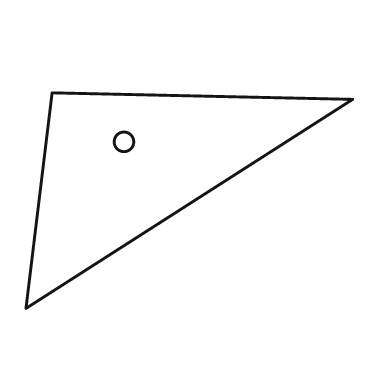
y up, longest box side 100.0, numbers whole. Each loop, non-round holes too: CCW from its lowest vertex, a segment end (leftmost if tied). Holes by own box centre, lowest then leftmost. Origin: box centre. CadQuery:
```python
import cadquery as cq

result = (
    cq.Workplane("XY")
    .moveTo(-50.0, -33.0)
    .lineTo(50.0, 31.0)
    .lineTo(-42.0, 33.0)
    .close()
    .moveTo(-20.0, 18.0)
    .circle(3.0)
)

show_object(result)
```